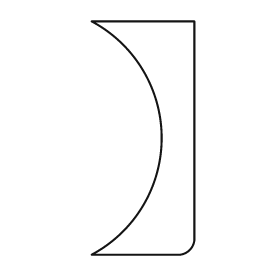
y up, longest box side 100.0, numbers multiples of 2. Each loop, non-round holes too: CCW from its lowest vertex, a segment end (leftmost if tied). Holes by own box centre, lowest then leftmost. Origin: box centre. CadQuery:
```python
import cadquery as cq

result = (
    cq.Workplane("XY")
    .moveTo(-22.0, -50.0)
    .lineTo(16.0, -50.0)
    .threePointArc((20.0, -48.0), (22.0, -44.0))
    .lineTo(22.0, 50.0)
    .lineTo(-22.0, 50.0)
    .threePointArc((8.0, 0.0), (-22.0, -50.0))
    .close()
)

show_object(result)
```